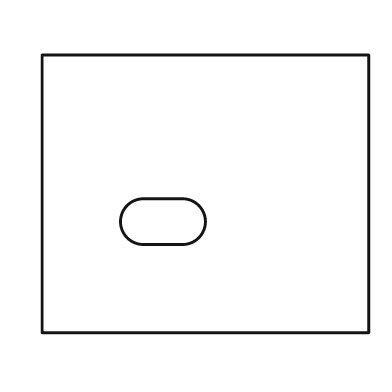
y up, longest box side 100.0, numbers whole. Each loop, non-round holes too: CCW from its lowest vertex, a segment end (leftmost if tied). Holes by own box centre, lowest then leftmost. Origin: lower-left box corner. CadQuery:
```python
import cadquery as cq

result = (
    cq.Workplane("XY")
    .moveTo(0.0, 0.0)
    .lineTo(100.0, 0.0)
    .lineTo(100.0, 85.0)
    .lineTo(0.0, 85.0)
    .close()
    .moveTo(31.0, 27.0)
    .lineTo(43.0, 27.0)
    .threePointArc((50.0, 34.0), (43.0, 41.0))
    .lineTo(31.0, 41.0)
    .threePointArc((24.0, 34.0), (31.0, 27.0))
    .close()
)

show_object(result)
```